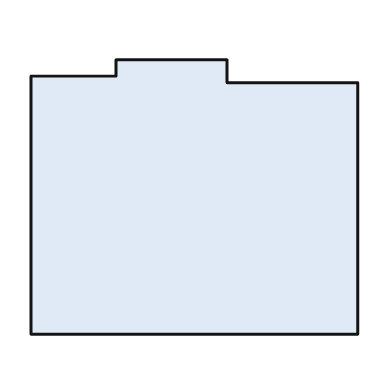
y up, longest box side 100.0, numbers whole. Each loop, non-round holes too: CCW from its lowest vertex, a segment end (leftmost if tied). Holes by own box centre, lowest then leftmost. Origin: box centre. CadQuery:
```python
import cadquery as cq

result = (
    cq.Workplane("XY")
    .moveTo(-50.0, -42.0)
    .lineTo(50.0, -42.0)
    .lineTo(50.0, 35.0)
    .lineTo(10.0, 35.0)
    .lineTo(10.0, 42.0)
    .lineTo(-24.0, 42.0)
    .lineTo(-24.0, 37.0)
    .lineTo(-50.0, 37.0)
    .close()
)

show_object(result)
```